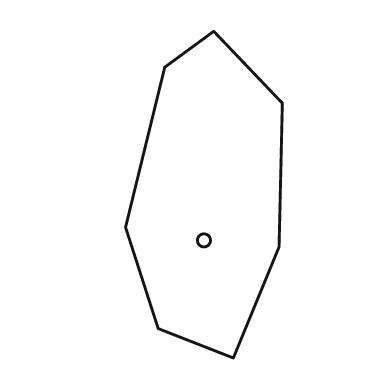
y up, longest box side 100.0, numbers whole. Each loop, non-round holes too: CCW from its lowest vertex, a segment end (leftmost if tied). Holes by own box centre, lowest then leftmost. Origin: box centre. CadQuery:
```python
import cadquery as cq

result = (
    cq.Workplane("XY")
    .moveTo(9.0, -50.0)
    .lineTo(23.0, -16.0)
    .lineTo(24.0, 28.0)
    .lineTo(3.0, 50.0)
    .lineTo(-12.0, 39.0)
    .lineTo(-24.0, -10.0)
    .lineTo(-14.0, -41.0)
    .close()
    .moveTo(0.0, -14.0)
    .circle(2.0)
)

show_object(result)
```